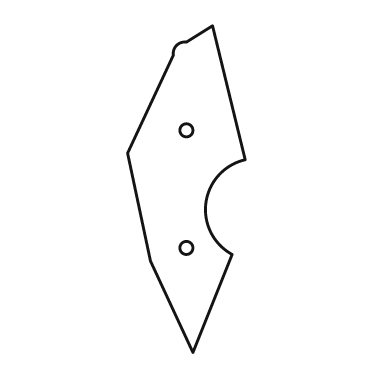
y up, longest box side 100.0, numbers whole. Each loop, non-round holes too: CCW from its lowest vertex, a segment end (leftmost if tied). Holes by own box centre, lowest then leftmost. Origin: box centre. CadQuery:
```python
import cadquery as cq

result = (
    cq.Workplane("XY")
    .moveTo(2.0, -50.0)
    .lineTo(14.0, -20.0)
    .threePointArc((6.0, -4.0), (18.0, 9.0))
    .lineTo(8.0, 50.0)
    .lineTo(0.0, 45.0)
    .threePointArc((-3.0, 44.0), (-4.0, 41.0))
    .lineTo(-18.0, 11.0)
    .lineTo(-11.0, -22.0)
    .close()
    .moveTo(0.0, -18.0)
    .circle(2.0)
    .moveTo(0.0, 18.0)
    .circle(2.0)
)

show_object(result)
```